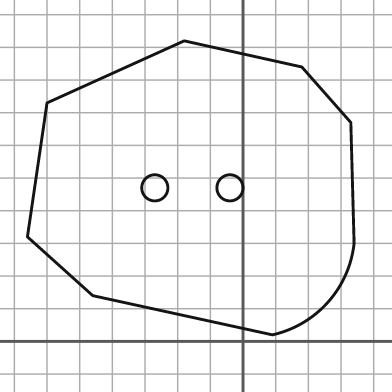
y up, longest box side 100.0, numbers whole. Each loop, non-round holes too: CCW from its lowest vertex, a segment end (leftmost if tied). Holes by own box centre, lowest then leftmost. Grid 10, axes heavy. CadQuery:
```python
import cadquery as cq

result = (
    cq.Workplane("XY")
    .moveTo(9.0, 2.0)
    .threePointArc((26.0, 12.0), (34.0, 30.0))
    .lineTo(33.0, 67.0)
    .lineTo(18.0, 84.0)
    .lineTo(-18.0, 92.0)
    .lineTo(-60.0, 73.0)
    .lineTo(-66.0, 32.0)
    .lineTo(-46.0, 14.0)
    .close()
    .moveTo(-27.0, 47.0)
    .circle(4.0)
    .moveTo(-4.0, 47.0)
    .circle(4.0)
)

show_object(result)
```